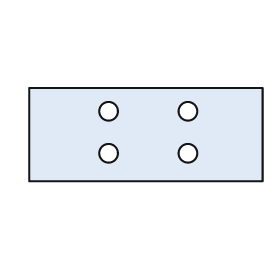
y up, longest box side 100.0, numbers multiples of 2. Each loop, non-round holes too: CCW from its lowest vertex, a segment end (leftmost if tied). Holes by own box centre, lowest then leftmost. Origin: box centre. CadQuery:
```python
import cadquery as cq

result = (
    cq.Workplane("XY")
    .moveTo(-50.0, -20.0)
    .lineTo(50.0, -20.0)
    .lineTo(50.0, 20.0)
    .lineTo(-50.0, 20.0)
    .close()
    .moveTo(-16.0, -8.0)
    .circle(4.0)
    .moveTo(18.0, -8.0)
    .circle(4.0)
    .moveTo(-16.0, 10.0)
    .circle(4.0)
    .moveTo(18.0, 10.0)
    .circle(4.0)
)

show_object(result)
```